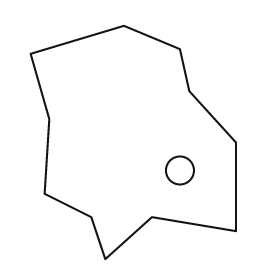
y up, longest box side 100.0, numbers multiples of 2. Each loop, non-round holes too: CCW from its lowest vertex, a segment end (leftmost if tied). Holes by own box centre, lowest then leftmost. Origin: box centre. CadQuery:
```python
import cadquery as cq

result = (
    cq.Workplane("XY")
    .moveTo(-12.0, -50.0)
    .lineTo(8.0, -32.0)
    .lineTo(44.0, -38.0)
    .lineTo(44.0, 0.0)
    .lineTo(24.0, 22.0)
    .lineTo(20.0, 40.0)
    .lineTo(-4.0, 50.0)
    .lineTo(-44.0, 38.0)
    .lineTo(-36.0, 10.0)
    .lineTo(-38.0, -22.0)
    .lineTo(-18.0, -32.0)
    .close()
    .moveTo(20.0, -12.0)
    .circle(6.0)
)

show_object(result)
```